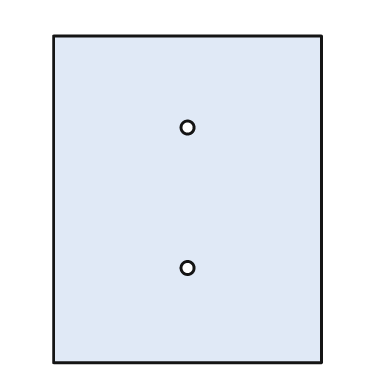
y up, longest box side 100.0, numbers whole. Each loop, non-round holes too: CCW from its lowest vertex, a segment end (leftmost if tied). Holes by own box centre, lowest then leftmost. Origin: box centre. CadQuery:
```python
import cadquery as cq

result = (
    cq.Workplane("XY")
    .moveTo(-41.0, -50.0)
    .lineTo(41.0, -50.0)
    .lineTo(41.0, 50.0)
    .lineTo(-41.0, 50.0)
    .close()
    .moveTo(0.0, -21.0)
    .circle(2.0)
    .moveTo(0.0, 22.0)
    .circle(2.0)
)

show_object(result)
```